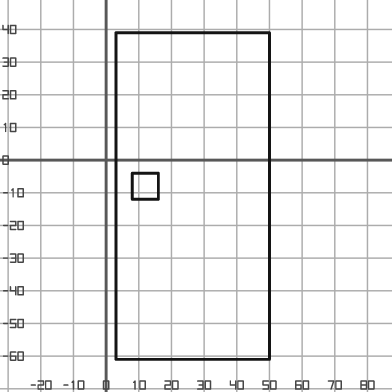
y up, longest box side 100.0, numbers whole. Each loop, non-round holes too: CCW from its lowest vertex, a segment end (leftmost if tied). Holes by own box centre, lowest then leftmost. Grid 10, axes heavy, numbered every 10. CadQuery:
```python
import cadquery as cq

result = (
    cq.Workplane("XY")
    .moveTo(3.0, -61.0)
    .lineTo(50.0, -61.0)
    .lineTo(50.0, 39.0)
    .lineTo(3.0, 39.0)
    .close()
    .moveTo(8.0, -12.0)
    .lineTo(16.0, -12.0)
    .lineTo(16.0, -4.0)
    .lineTo(8.0, -4.0)
    .close()
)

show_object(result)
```